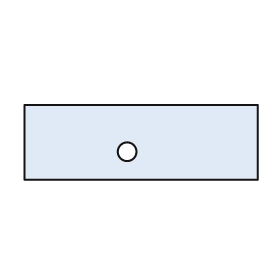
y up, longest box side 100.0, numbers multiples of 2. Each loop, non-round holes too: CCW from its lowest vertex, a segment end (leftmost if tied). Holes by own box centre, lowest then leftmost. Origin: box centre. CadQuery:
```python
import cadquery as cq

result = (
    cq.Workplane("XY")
    .moveTo(-50.0, -16.0)
    .lineTo(50.0, -16.0)
    .lineTo(50.0, 16.0)
    .lineTo(-50.0, 16.0)
    .close()
    .moveTo(-6.0, -4.0)
    .circle(4.0)
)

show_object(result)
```